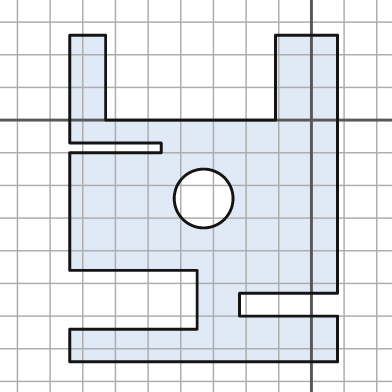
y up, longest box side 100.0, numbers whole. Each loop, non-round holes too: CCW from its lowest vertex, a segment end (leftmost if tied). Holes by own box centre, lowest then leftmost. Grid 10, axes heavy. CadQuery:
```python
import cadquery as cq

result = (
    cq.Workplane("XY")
    .moveTo(-74.0, -74.0)
    .lineTo(8.0, -74.0)
    .lineTo(8.0, -60.0)
    .lineTo(-22.0, -60.0)
    .lineTo(-22.0, -53.0)
    .lineTo(8.0, -53.0)
    .lineTo(8.0, 26.0)
    .lineTo(-11.0, 26.0)
    .lineTo(-11.0, 0.0)
    .lineTo(-63.0, 0.0)
    .lineTo(-63.0, 26.0)
    .lineTo(-74.0, 26.0)
    .lineTo(-74.0, -7.0)
    .lineTo(-46.0, -7.0)
    .lineTo(-46.0, -10.0)
    .lineTo(-74.0, -10.0)
    .lineTo(-74.0, -46.0)
    .lineTo(-35.0, -46.0)
    .lineTo(-35.0, -64.0)
    .lineTo(-74.0, -64.0)
    .close()
    .moveTo(-33.0, -24.0)
    .circle(9.0)
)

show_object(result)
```